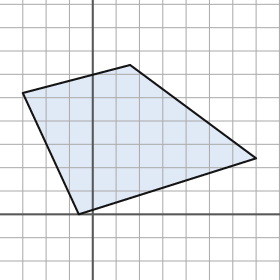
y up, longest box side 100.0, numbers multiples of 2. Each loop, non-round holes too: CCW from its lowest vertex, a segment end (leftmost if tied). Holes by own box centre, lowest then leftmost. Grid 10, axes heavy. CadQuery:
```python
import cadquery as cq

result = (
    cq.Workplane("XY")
    .moveTo(-6.0, 0.0)
    .lineTo(70.0, 24.0)
    .lineTo(16.0, 64.0)
    .lineTo(-30.0, 52.0)
    .close()
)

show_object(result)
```